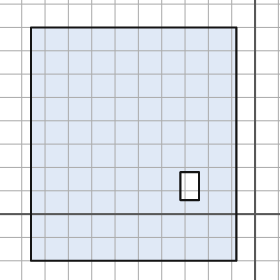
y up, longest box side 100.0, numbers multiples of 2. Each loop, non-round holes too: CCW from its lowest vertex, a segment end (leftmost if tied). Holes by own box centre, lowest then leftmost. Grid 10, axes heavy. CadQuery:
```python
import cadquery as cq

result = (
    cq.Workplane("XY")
    .moveTo(-96.0, -20.0)
    .lineTo(-8.0, -20.0)
    .lineTo(-8.0, 80.0)
    .lineTo(-96.0, 80.0)
    .close()
    .moveTo(-32.0, 6.0)
    .lineTo(-24.0, 6.0)
    .lineTo(-24.0, 18.0)
    .lineTo(-32.0, 18.0)
    .close()
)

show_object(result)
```